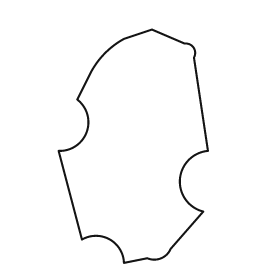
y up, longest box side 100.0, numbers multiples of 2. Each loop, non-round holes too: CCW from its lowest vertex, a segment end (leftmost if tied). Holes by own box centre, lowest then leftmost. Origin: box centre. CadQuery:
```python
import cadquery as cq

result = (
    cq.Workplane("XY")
    .moveTo(-4.0, -50.0)
    .lineTo(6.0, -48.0)
    .threePointArc((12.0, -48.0), (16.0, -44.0))
    .lineTo(30.0, -28.0)
    .threePointArc((20.0, -14.0), (32.0, -2.0))
    .lineTo(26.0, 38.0)
    .threePointArc((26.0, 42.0), (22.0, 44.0))
    .lineTo(8.0, 50.0)
    .lineTo(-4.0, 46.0)
    .threePointArc((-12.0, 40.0), (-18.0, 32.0))
    .lineTo(-24.0, 20.0)
    .threePointArc((-20.0, 6.0), (-32.0, -2.0))
    .lineTo(-22.0, -40.0)
    .threePointArc((-10.0, -40.0), (-4.0, -50.0))
    .close()
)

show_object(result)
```